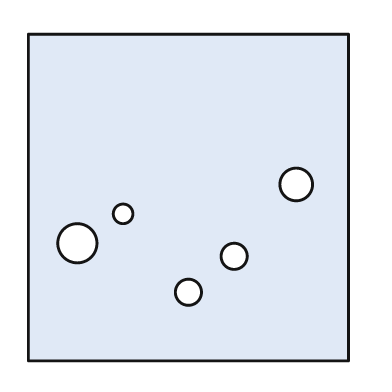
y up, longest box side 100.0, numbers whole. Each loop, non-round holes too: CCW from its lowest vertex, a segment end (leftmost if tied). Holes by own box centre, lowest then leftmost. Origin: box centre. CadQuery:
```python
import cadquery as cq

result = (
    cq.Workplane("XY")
    .moveTo(-49.0, -50.0)
    .lineTo(49.0, -50.0)
    .lineTo(49.0, 50.0)
    .lineTo(-49.0, 50.0)
    .close()
    .moveTo(0.0, -29.0)
    .circle(4.0)
    .moveTo(14.0, -18.0)
    .circle(4.0)
    .moveTo(-34.0, -14.0)
    .circle(6.0)
    .moveTo(-20.0, -5.0)
    .circle(3.0)
    .moveTo(33.0, 4.0)
    .circle(5.0)
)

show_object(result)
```